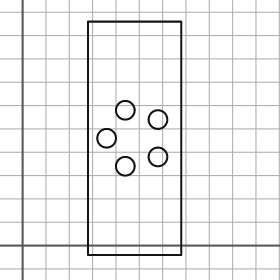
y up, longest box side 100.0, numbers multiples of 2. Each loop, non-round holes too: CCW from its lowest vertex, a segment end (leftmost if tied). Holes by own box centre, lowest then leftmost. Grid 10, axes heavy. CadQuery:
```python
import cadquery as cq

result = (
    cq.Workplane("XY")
    .moveTo(28.0, -4.0)
    .lineTo(68.0, -4.0)
    .lineTo(68.0, 96.0)
    .lineTo(28.0, 96.0)
    .close()
    .moveTo(44.0, 34.0)
    .circle(4.0)
    .moveTo(58.0, 38.0)
    .circle(4.0)
    .moveTo(36.0, 46.0)
    .circle(4.0)
    .moveTo(58.0, 54.0)
    .circle(4.0)
    .moveTo(44.0, 58.0)
    .circle(4.0)
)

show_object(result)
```